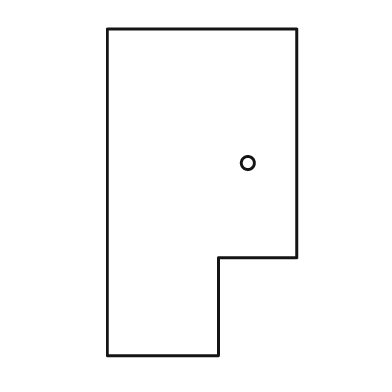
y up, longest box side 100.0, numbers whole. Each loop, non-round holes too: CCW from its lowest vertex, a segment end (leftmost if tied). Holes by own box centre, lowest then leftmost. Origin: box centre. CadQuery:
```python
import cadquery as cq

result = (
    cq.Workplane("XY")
    .moveTo(-29.0, -50.0)
    .lineTo(5.0, -50.0)
    .lineTo(5.0, -20.0)
    .lineTo(29.0, -20.0)
    .lineTo(29.0, 50.0)
    .lineTo(-29.0, 50.0)
    .close()
    .moveTo(14.0, 9.0)
    .circle(2.0)
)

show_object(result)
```